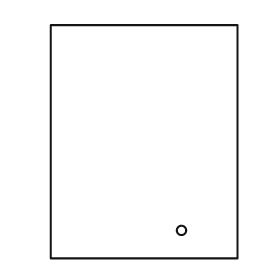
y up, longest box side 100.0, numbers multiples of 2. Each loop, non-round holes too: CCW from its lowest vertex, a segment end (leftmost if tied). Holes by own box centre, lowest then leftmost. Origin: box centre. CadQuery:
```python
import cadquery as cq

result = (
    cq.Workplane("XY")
    .moveTo(-40.0, -50.0)
    .lineTo(40.0, -50.0)
    .lineTo(40.0, 50.0)
    .lineTo(-40.0, 50.0)
    .close()
    .moveTo(16.0, -38.0)
    .circle(2.0)
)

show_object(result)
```